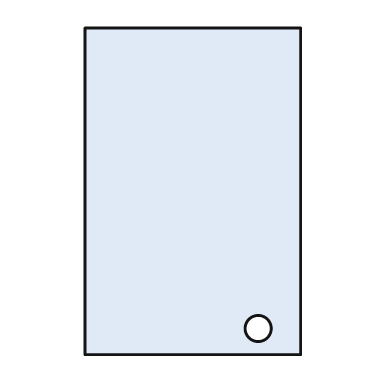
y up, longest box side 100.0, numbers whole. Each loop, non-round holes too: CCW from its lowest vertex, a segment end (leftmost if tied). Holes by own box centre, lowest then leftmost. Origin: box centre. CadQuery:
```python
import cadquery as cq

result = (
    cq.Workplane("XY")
    .moveTo(-33.0, -50.0)
    .lineTo(33.0, -50.0)
    .lineTo(33.0, 50.0)
    .lineTo(-33.0, 50.0)
    .close()
    .moveTo(20.0, -42.0)
    .circle(4.0)
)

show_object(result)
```